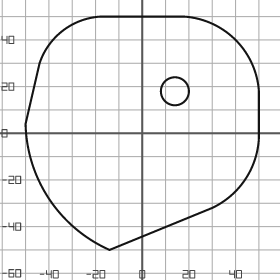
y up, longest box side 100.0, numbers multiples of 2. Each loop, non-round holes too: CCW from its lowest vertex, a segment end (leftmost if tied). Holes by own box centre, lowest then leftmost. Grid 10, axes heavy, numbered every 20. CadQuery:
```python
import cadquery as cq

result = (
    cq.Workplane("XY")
    .moveTo(-14.0, -50.0)
    .lineTo(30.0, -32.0)
    .threePointArc((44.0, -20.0), (50.0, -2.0))
    .lineTo(50.0, 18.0)
    .threePointArc((40.0, 40.0), (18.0, 50.0))
    .lineTo(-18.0, 50.0)
    .threePointArc((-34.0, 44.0), (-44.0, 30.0))
    .lineTo(-50.0, 4.0)
    .threePointArc((-40.0, -28.0), (-14.0, -50.0))
    .close()
    .moveTo(14.0, 18.0)
    .circle(6.0)
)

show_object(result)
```